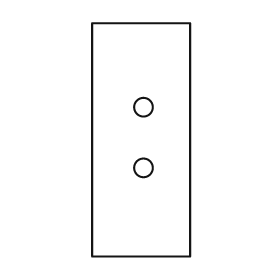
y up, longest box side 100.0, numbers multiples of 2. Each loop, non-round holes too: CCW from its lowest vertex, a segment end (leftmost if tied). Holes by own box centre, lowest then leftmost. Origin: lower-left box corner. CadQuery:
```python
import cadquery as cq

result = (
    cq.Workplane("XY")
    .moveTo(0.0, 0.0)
    .lineTo(42.0, 0.0)
    .lineTo(42.0, 100.0)
    .lineTo(0.0, 100.0)
    .close()
    .moveTo(22.0, 38.0)
    .circle(4.0)
    .moveTo(22.0, 64.0)
    .circle(4.0)
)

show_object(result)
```